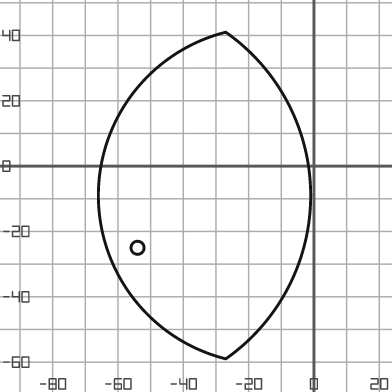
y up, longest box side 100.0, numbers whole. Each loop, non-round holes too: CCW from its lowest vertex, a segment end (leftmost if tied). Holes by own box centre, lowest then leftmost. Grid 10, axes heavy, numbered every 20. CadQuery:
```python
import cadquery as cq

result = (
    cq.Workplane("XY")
    .moveTo(-27.0, -59.0)
    .threePointArc((-1.0, -9.0), (-27.0, 41.0))
    .threePointArc((-66.0, -9.0), (-27.0, -59.0))
    .close()
    .moveTo(-54.0, -25.0)
    .circle(2.0)
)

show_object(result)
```